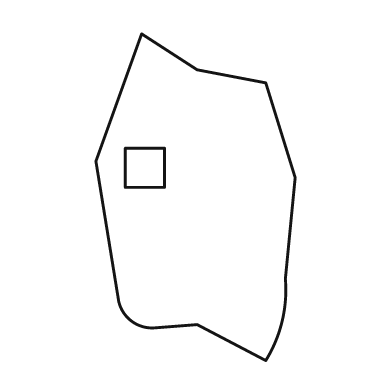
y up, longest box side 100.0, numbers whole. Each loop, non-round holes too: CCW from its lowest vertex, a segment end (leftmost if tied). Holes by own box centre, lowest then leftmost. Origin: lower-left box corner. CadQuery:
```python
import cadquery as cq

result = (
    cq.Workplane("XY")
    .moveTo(52.0, 0.0)
    .threePointArc((57.0, 12.0), (58.0, 25.0))
    .lineTo(61.0, 56.0)
    .lineTo(52.0, 85.0)
    .lineTo(31.0, 89.0)
    .lineTo(14.0, 100.0)
    .lineTo(0.0, 61.0)
    .lineTo(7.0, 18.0)
    .threePointArc((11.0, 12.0), (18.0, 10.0))
    .lineTo(31.0, 11.0)
    .close()
    .moveTo(9.0, 53.0)
    .lineTo(21.0, 53.0)
    .lineTo(21.0, 65.0)
    .lineTo(9.0, 65.0)
    .close()
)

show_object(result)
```